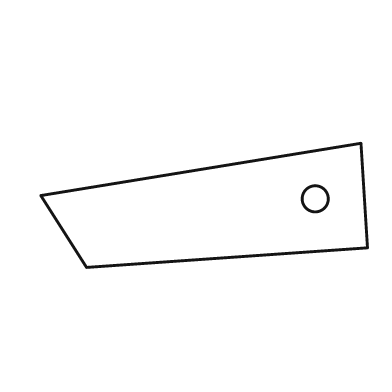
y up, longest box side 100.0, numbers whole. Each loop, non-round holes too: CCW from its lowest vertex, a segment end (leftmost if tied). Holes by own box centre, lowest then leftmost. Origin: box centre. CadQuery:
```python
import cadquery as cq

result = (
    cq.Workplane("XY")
    .moveTo(-36.0, -19.0)
    .lineTo(50.0, -13.0)
    .lineTo(48.0, 19.0)
    .lineTo(-50.0, 3.0)
    .close()
    .moveTo(34.0, 2.0)
    .circle(4.0)
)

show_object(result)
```